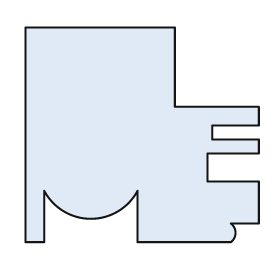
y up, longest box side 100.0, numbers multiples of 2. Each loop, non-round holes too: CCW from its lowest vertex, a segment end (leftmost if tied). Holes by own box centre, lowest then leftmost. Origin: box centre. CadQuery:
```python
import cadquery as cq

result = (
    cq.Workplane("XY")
    .moveTo(-50.0, -46.0)
    .lineTo(-42.0, -46.0)
    .lineTo(-42.0, -24.0)
    .threePointArc((-22.0, -36.0), (-2.0, -24.0))
    .lineTo(-2.0, -46.0)
    .lineTo(38.0, -46.0)
    .threePointArc((40.0, -42.0), (38.0, -38.0))
    .lineTo(50.0, -38.0)
    .lineTo(50.0, -20.0)
    .lineTo(28.0, -20.0)
    .lineTo(28.0, -8.0)
    .lineTo(50.0, -8.0)
    .lineTo(50.0, -2.0)
    .lineTo(30.0, -2.0)
    .lineTo(30.0, 4.0)
    .lineTo(50.0, 4.0)
    .lineTo(50.0, 12.0)
    .lineTo(14.0, 12.0)
    .lineTo(14.0, 46.0)
    .lineTo(-50.0, 46.0)
    .close()
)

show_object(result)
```